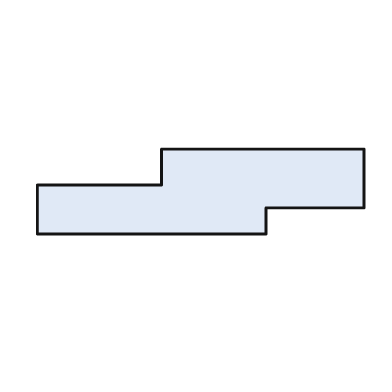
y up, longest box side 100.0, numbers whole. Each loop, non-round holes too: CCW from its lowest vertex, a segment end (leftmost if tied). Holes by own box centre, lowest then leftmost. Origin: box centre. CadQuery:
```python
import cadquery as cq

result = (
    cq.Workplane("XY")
    .moveTo(-50.0, -13.0)
    .lineTo(20.0, -13.0)
    .lineTo(20.0, -5.0)
    .lineTo(50.0, -5.0)
    .lineTo(50.0, 13.0)
    .lineTo(-12.0, 13.0)
    .lineTo(-12.0, 2.0)
    .lineTo(-50.0, 2.0)
    .close()
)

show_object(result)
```